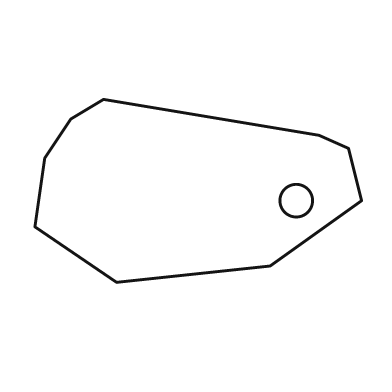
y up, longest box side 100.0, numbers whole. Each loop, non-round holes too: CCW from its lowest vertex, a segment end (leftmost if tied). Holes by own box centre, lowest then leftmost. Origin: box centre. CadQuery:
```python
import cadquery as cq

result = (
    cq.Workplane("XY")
    .moveTo(-25.0, -28.0)
    .lineTo(22.0, -23.0)
    .lineTo(50.0, -3.0)
    .lineTo(46.0, 13.0)
    .lineTo(37.0, 17.0)
    .lineTo(-29.0, 28.0)
    .lineTo(-39.0, 22.0)
    .lineTo(-47.0, 10.0)
    .lineTo(-50.0, -11.0)
    .close()
    .moveTo(30.0, -3.0)
    .circle(5.0)
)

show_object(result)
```